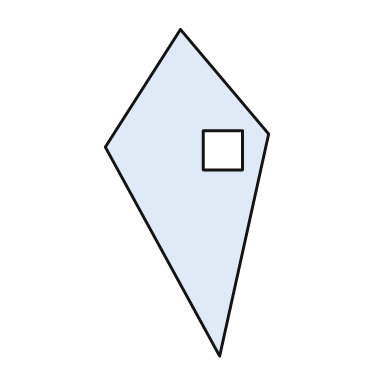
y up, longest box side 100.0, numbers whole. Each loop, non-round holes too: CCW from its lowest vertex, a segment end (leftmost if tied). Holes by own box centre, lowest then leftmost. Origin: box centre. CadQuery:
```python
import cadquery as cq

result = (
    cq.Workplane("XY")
    .moveTo(10.0, -50.0)
    .lineTo(25.0, 18.0)
    .lineTo(-2.0, 50.0)
    .lineTo(-25.0, 14.0)
    .close()
    .moveTo(5.0, 7.0)
    .lineTo(17.0, 7.0)
    .lineTo(17.0, 19.0)
    .lineTo(5.0, 19.0)
    .close()
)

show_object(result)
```